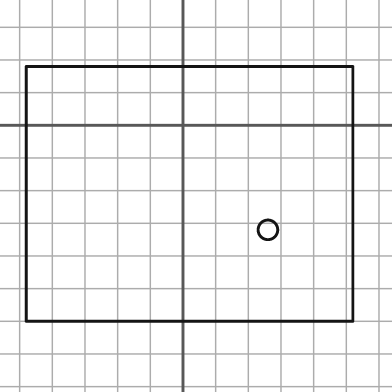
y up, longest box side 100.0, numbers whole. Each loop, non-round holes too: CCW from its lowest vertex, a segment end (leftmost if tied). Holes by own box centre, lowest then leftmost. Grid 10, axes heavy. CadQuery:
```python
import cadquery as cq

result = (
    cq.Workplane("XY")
    .moveTo(-48.0, -60.0)
    .lineTo(52.0, -60.0)
    .lineTo(52.0, 18.0)
    .lineTo(-48.0, 18.0)
    .close()
    .moveTo(26.0, -32.0)
    .circle(3.0)
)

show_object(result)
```